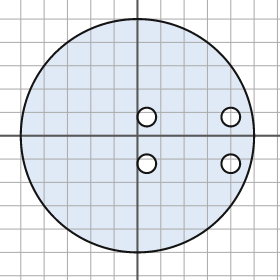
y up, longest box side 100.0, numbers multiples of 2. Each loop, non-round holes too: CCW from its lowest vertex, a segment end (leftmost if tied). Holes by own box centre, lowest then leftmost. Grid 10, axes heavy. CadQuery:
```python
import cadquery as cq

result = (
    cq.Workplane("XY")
    .moveTo(0.0, 0.0)
    .circle(50.0)
    .moveTo(4.0, -12.0)
    .circle(4.0)
    .moveTo(40.0, -12.0)
    .circle(4.0)
    .moveTo(4.0, 8.0)
    .circle(4.0)
    .moveTo(40.0, 8.0)
    .circle(4.0)
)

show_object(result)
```